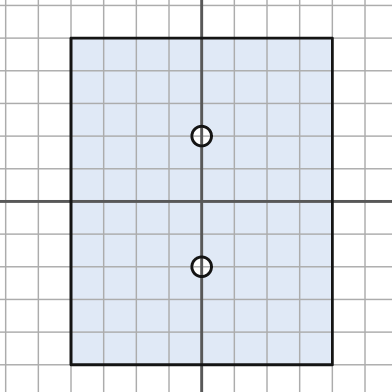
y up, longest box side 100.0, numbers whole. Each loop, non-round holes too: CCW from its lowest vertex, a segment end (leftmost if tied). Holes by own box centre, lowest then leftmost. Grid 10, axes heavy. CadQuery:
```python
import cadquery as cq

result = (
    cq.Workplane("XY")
    .moveTo(-40.0, -50.0)
    .lineTo(40.0, -50.0)
    .lineTo(40.0, 50.0)
    .lineTo(-40.0, 50.0)
    .close()
    .moveTo(0.0, -20.0)
    .circle(3.0)
    .moveTo(0.0, 20.0)
    .circle(3.0)
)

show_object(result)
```